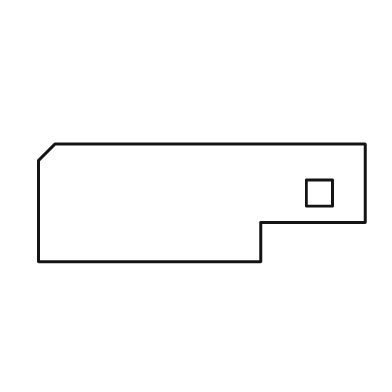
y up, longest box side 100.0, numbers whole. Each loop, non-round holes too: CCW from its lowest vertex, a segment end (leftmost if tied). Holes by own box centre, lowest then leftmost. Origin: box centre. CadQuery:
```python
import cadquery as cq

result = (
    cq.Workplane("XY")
    .moveTo(-50.0, -18.0)
    .lineTo(18.0, -18.0)
    .lineTo(18.0, -6.0)
    .lineTo(50.0, -6.0)
    .lineTo(50.0, 18.0)
    .lineTo(-45.0, 18.0)
    .lineTo(-50.0, 13.0)
    .close()
    .moveTo(32.0, -1.0)
    .lineTo(40.0, -1.0)
    .lineTo(40.0, 7.0)
    .lineTo(32.0, 7.0)
    .close()
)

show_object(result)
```